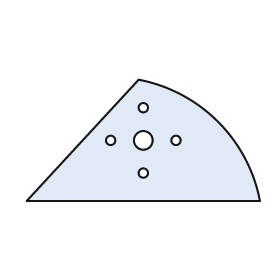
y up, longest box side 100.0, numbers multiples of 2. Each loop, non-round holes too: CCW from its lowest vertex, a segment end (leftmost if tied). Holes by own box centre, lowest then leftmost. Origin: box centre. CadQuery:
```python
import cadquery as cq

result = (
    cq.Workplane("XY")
    .moveTo(-50.0, -26.0)
    .lineTo(50.0, -26.0)
    .threePointArc((32.0, 8.0), (-2.0, 26.0))
    .close()
    .moveTo(0.0, -14.0)
    .circle(2.0)
    .moveTo(-14.0, 0.0)
    .circle(2.0)
    .moveTo(0.0, 0.0)
    .circle(4.0)
    .moveTo(14.0, 0.0)
    .circle(2.0)
    .moveTo(0.0, 14.0)
    .circle(2.0)
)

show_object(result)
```